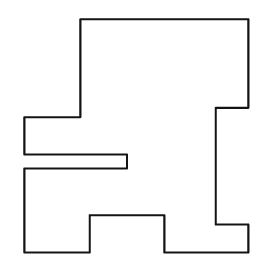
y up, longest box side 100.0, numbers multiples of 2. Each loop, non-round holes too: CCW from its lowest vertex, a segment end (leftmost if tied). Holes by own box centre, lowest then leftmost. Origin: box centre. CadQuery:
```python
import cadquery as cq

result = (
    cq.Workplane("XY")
    .moveTo(-48.0, -50.0)
    .lineTo(-20.0, -50.0)
    .lineTo(-20.0, -34.0)
    .lineTo(12.0, -34.0)
    .lineTo(12.0, -50.0)
    .lineTo(48.0, -50.0)
    .lineTo(48.0, -38.0)
    .lineTo(34.0, -38.0)
    .lineTo(34.0, 12.0)
    .lineTo(48.0, 12.0)
    .lineTo(48.0, 50.0)
    .lineTo(-24.0, 50.0)
    .lineTo(-24.0, 8.0)
    .lineTo(-48.0, 8.0)
    .lineTo(-48.0, -8.0)
    .lineTo(-4.0, -8.0)
    .lineTo(-4.0, -14.0)
    .lineTo(-48.0, -14.0)
    .close()
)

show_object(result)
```